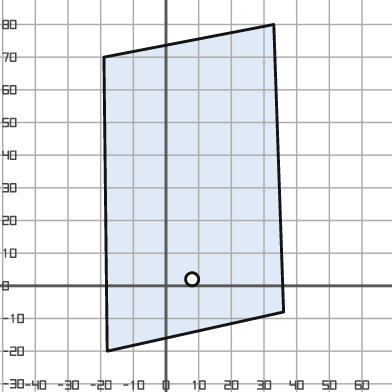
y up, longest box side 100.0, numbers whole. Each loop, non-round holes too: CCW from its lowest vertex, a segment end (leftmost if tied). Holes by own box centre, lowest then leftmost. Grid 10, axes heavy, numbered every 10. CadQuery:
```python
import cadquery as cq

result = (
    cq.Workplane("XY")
    .moveTo(-18.0, -20.0)
    .lineTo(36.0, -8.0)
    .lineTo(33.0, 80.0)
    .lineTo(-19.0, 70.0)
    .close()
    .moveTo(8.0, 2.0)
    .circle(2.0)
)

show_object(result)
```